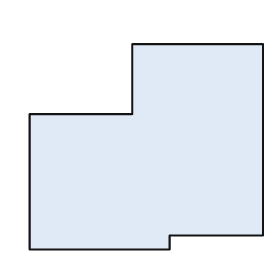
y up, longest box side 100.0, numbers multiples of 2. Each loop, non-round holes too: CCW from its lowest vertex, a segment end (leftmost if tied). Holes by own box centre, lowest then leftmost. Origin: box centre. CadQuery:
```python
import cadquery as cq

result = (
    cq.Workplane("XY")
    .moveTo(-50.0, -44.0)
    .lineTo(10.0, -44.0)
    .lineTo(10.0, -38.0)
    .lineTo(50.0, -38.0)
    .lineTo(50.0, 44.0)
    .lineTo(-6.0, 44.0)
    .lineTo(-6.0, 14.0)
    .lineTo(-50.0, 14.0)
    .close()
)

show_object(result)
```